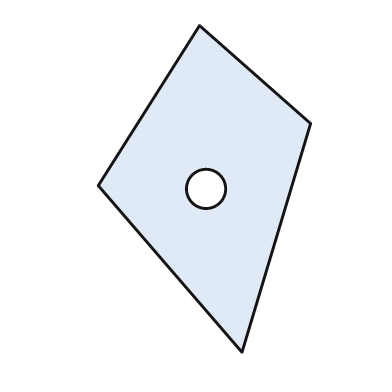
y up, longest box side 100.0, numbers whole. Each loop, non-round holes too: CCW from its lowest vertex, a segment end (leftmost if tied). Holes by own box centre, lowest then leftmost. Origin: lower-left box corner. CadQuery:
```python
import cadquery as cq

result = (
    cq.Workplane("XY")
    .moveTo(44.0, 0.0)
    .lineTo(65.0, 70.0)
    .lineTo(31.0, 100.0)
    .lineTo(0.0, 51.0)
    .close()
    .moveTo(33.0, 50.0)
    .circle(6.0)
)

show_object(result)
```